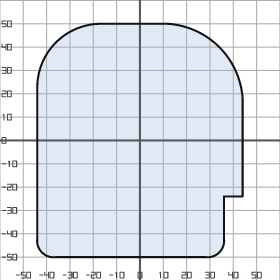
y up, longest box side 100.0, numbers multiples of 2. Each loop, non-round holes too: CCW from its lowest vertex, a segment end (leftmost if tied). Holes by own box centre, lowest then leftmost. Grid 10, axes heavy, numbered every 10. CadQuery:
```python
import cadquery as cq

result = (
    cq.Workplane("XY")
    .moveTo(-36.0, -50.0)
    .lineTo(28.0, -50.0)
    .threePointArc((34.0, -48.0), (36.0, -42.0))
    .lineTo(36.0, -24.0)
    .lineTo(44.0, -24.0)
    .lineTo(44.0, 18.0)
    .threePointArc((34.0, 40.0), (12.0, 50.0))
    .lineTo(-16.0, 50.0)
    .threePointArc((-36.0, 42.0), (-44.0, 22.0))
    .lineTo(-44.0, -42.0)
    .threePointArc((-42.0, -48.0), (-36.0, -50.0))
    .close()
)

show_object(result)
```